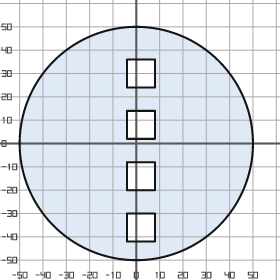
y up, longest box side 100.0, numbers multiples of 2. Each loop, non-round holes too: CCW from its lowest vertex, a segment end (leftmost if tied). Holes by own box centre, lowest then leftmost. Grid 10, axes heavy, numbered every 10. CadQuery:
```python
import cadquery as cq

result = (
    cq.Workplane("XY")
    .moveTo(0.0, 0.0)
    .circle(50.0)
    .moveTo(-4.0, -42.0)
    .lineTo(8.0, -42.0)
    .lineTo(8.0, -30.0)
    .lineTo(-4.0, -30.0)
    .close()
    .moveTo(-4.0, -20.0)
    .lineTo(8.0, -20.0)
    .lineTo(8.0, -8.0)
    .lineTo(-4.0, -8.0)
    .close()
    .moveTo(-4.0, 2.0)
    .lineTo(8.0, 2.0)
    .lineTo(8.0, 14.0)
    .lineTo(-4.0, 14.0)
    .close()
    .moveTo(-4.0, 24.0)
    .lineTo(8.0, 24.0)
    .lineTo(8.0, 36.0)
    .lineTo(-4.0, 36.0)
    .close()
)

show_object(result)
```